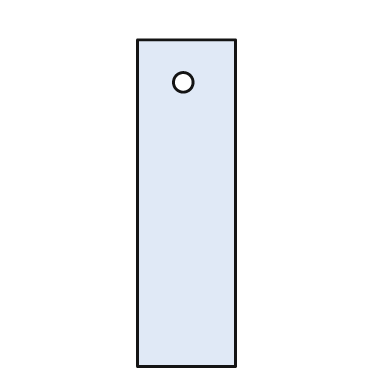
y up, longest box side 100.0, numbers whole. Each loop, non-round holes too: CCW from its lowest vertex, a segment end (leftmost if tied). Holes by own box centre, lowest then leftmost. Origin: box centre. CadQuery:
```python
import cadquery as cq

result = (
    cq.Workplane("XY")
    .moveTo(-15.0, -50.0)
    .lineTo(15.0, -50.0)
    .lineTo(15.0, 50.0)
    .lineTo(-15.0, 50.0)
    .close()
    .moveTo(-1.0, 37.0)
    .circle(3.0)
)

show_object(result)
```